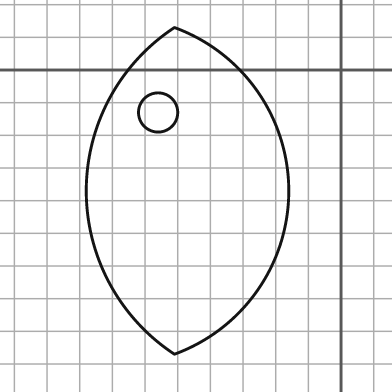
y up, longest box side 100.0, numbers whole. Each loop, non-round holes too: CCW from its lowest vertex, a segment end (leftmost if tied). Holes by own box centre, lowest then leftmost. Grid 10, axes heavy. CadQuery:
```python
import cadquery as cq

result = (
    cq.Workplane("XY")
    .moveTo(-51.0, -87.0)
    .threePointArc((-16.0, -37.0), (-51.0, 13.0))
    .threePointArc((-78.0, -37.0), (-51.0, -87.0))
    .close()
    .moveTo(-56.0, -13.0)
    .circle(6.0)
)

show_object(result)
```